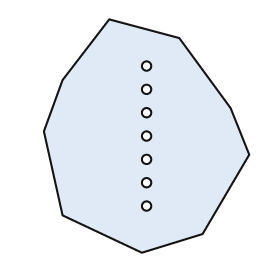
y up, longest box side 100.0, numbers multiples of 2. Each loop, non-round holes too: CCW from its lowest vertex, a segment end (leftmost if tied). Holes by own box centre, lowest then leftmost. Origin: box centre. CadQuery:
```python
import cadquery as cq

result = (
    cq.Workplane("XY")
    .moveTo(-2.0, -50.0)
    .lineTo(24.0, -42.0)
    .lineTo(44.0, -8.0)
    .lineTo(36.0, 12.0)
    .lineTo(14.0, 42.0)
    .lineTo(-16.0, 50.0)
    .lineTo(-36.0, 24.0)
    .lineTo(-44.0, 2.0)
    .lineTo(-36.0, -34.0)
    .close()
    .moveTo(0.0, -30.0)
    .circle(2.0)
    .moveTo(0.0, -20.0)
    .circle(2.0)
    .moveTo(0.0, -10.0)
    .circle(2.0)
    .moveTo(0.0, 0.0)
    .circle(2.0)
    .moveTo(0.0, 10.0)
    .circle(2.0)
    .moveTo(0.0, 20.0)
    .circle(2.0)
    .moveTo(0.0, 30.0)
    .circle(2.0)
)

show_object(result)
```